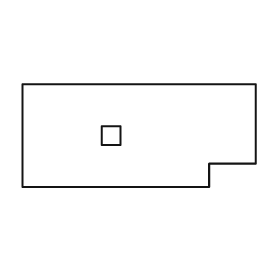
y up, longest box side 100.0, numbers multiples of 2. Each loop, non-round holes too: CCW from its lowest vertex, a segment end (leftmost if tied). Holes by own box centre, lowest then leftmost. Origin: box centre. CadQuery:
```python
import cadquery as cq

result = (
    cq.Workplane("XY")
    .moveTo(-50.0, -22.0)
    .lineTo(30.0, -22.0)
    .lineTo(30.0, -12.0)
    .lineTo(50.0, -12.0)
    .lineTo(50.0, 22.0)
    .lineTo(-50.0, 22.0)
    .close()
    .moveTo(-16.0, -4.0)
    .lineTo(-8.0, -4.0)
    .lineTo(-8.0, 4.0)
    .lineTo(-16.0, 4.0)
    .close()
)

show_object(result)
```